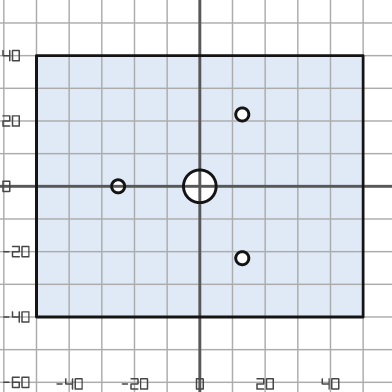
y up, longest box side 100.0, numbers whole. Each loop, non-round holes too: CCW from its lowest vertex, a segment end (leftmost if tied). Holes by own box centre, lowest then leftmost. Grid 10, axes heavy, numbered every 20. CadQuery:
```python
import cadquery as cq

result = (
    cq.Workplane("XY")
    .moveTo(-50.0, -40.0)
    .lineTo(50.0, -40.0)
    .lineTo(50.0, 40.0)
    .lineTo(-50.0, 40.0)
    .close()
    .moveTo(13.0, -22.0)
    .circle(2.0)
    .moveTo(-25.0, 0.0)
    .circle(2.0)
    .moveTo(0.0, 0.0)
    .circle(5.0)
    .moveTo(13.0, 22.0)
    .circle(2.0)
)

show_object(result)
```